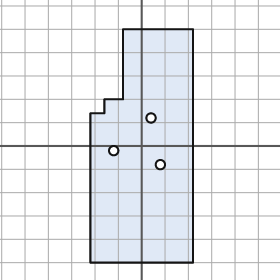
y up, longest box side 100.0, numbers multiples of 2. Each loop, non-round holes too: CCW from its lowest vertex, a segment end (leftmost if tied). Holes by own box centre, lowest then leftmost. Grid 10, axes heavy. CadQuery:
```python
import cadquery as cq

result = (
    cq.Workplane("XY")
    .moveTo(-22.0, -50.0)
    .lineTo(22.0, -50.0)
    .lineTo(22.0, 50.0)
    .lineTo(-8.0, 50.0)
    .lineTo(-8.0, 20.0)
    .lineTo(-16.0, 20.0)
    .lineTo(-16.0, 14.0)
    .lineTo(-22.0, 14.0)
    .close()
    .moveTo(8.0, -8.0)
    .circle(2.0)
    .moveTo(-12.0, -2.0)
    .circle(2.0)
    .moveTo(4.0, 12.0)
    .circle(2.0)
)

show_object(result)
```